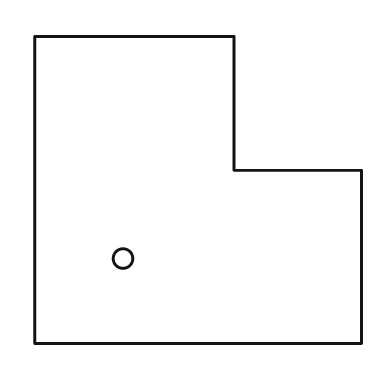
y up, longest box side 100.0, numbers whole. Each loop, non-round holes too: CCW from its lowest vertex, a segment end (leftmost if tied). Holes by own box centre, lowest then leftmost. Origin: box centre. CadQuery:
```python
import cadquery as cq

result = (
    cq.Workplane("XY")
    .moveTo(-50.0, -47.0)
    .lineTo(50.0, -47.0)
    .lineTo(50.0, 6.0)
    .lineTo(11.0, 6.0)
    .lineTo(11.0, 47.0)
    .lineTo(-50.0, 47.0)
    .close()
    .moveTo(-23.0, -21.0)
    .circle(3.0)
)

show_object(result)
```